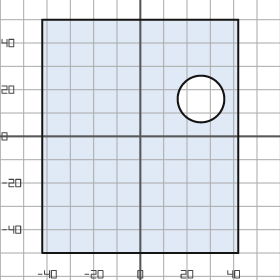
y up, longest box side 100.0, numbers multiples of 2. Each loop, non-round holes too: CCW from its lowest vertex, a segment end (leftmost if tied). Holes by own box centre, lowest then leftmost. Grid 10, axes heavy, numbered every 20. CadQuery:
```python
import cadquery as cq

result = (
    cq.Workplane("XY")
    .moveTo(-42.0, -50.0)
    .lineTo(42.0, -50.0)
    .lineTo(42.0, 50.0)
    .lineTo(-42.0, 50.0)
    .close()
    .moveTo(26.0, 16.0)
    .circle(10.0)
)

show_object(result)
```